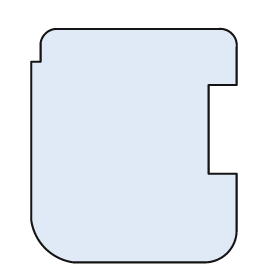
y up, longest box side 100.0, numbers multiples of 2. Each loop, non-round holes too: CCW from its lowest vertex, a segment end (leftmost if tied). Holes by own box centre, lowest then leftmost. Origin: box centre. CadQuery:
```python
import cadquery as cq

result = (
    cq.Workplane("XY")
    .moveTo(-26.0, -50.0)
    .lineTo(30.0, -50.0)
    .threePointArc((40.0, -46.0), (44.0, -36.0))
    .lineTo(44.0, -12.0)
    .lineTo(32.0, -12.0)
    .lineTo(32.0, 26.0)
    .lineTo(44.0, 26.0)
    .lineTo(44.0, 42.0)
    .threePointArc((42.0, 48.0), (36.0, 50.0))
    .lineTo(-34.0, 50.0)
    .threePointArc((-38.0, 48.0), (-40.0, 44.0))
    .lineTo(-40.0, 36.0)
    .lineTo(-44.0, 36.0)
    .lineTo(-44.0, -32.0)
    .threePointArc((-38.0, -44.0), (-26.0, -50.0))
    .close()
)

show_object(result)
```